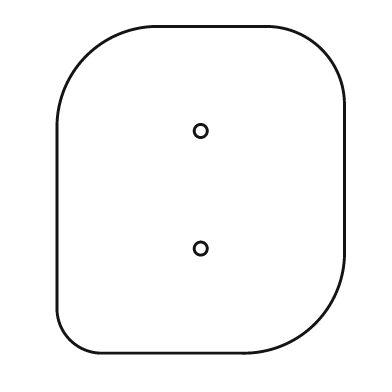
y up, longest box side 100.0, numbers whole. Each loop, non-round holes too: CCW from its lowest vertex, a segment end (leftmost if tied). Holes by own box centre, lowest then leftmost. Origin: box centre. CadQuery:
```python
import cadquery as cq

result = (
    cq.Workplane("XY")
    .moveTo(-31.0, -50.0)
    .lineTo(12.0, -50.0)
    .threePointArc((35.0, -41.0), (44.0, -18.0))
    .lineTo(44.0, 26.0)
    .threePointArc((37.0, 43.0), (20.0, 50.0))
    .lineTo(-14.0, 50.0)
    .threePointArc((-35.0, 41.0), (-44.0, 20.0))
    .lineTo(-44.0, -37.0)
    .threePointArc((-40.0, -46.0), (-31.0, -50.0))
    .close()
    .moveTo(0.0, -18.0)
    .circle(2.0)
    .moveTo(0.0, 18.0)
    .circle(2.0)
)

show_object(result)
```